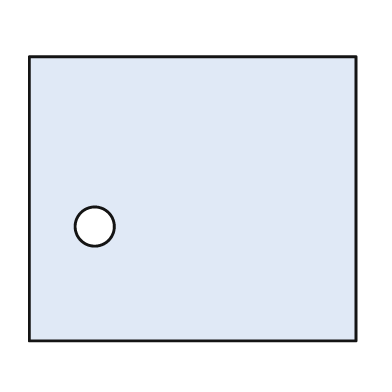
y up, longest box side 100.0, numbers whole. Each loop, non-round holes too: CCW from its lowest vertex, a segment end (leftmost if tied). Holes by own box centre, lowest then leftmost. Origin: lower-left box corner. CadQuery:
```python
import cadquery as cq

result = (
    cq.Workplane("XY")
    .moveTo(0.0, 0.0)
    .lineTo(100.0, 0.0)
    .lineTo(100.0, 87.0)
    .lineTo(0.0, 87.0)
    .close()
    .moveTo(20.0, 35.0)
    .circle(6.0)
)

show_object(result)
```